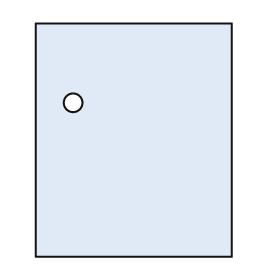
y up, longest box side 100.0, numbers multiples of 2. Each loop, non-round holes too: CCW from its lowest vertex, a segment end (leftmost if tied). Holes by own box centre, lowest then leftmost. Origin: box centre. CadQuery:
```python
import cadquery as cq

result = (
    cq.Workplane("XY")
    .moveTo(-42.0, -50.0)
    .lineTo(42.0, -50.0)
    .lineTo(42.0, 50.0)
    .lineTo(-42.0, 50.0)
    .close()
    .moveTo(-26.0, 16.0)
    .circle(4.0)
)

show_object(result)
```